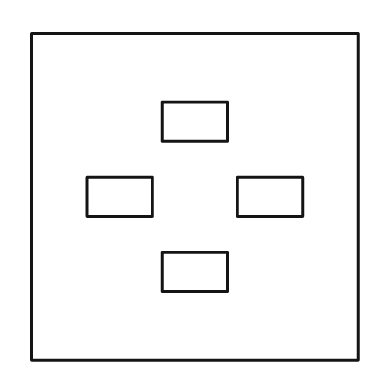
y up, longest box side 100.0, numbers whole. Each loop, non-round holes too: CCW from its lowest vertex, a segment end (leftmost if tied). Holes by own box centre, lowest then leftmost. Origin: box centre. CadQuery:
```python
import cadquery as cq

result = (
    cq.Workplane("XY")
    .moveTo(-50.0, -50.0)
    .lineTo(50.0, -50.0)
    .lineTo(50.0, 50.0)
    .lineTo(-50.0, 50.0)
    .close()
    .moveTo(-10.0, -29.0)
    .lineTo(10.0, -29.0)
    .lineTo(10.0, -17.0)
    .lineTo(-10.0, -17.0)
    .close()
    .moveTo(-33.0, -6.0)
    .lineTo(-13.0, -6.0)
    .lineTo(-13.0, 6.0)
    .lineTo(-33.0, 6.0)
    .close()
    .moveTo(13.0, -6.0)
    .lineTo(33.0, -6.0)
    .lineTo(33.0, 6.0)
    .lineTo(13.0, 6.0)
    .close()
    .moveTo(-10.0, 17.0)
    .lineTo(10.0, 17.0)
    .lineTo(10.0, 29.0)
    .lineTo(-10.0, 29.0)
    .close()
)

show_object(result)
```